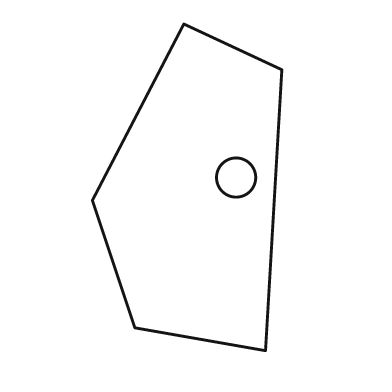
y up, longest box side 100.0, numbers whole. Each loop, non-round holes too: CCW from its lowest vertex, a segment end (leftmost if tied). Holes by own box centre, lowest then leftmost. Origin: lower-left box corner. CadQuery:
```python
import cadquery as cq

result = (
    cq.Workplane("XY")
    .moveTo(53.0, 0.0)
    .lineTo(58.0, 86.0)
    .lineTo(28.0, 100.0)
    .lineTo(0.0, 46.0)
    .lineTo(13.0, 7.0)
    .close()
    .moveTo(44.0, 53.0)
    .circle(6.0)
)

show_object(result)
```